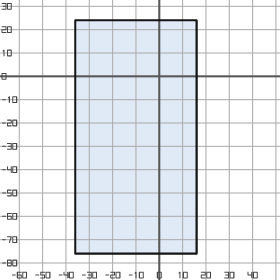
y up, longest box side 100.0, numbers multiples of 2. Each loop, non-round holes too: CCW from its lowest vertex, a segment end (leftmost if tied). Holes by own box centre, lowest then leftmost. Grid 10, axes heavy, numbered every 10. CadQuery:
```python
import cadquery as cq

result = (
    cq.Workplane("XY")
    .moveTo(-36.0, -76.0)
    .lineTo(16.0, -76.0)
    .lineTo(16.0, 24.0)
    .lineTo(-36.0, 24.0)
    .close()
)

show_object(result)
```